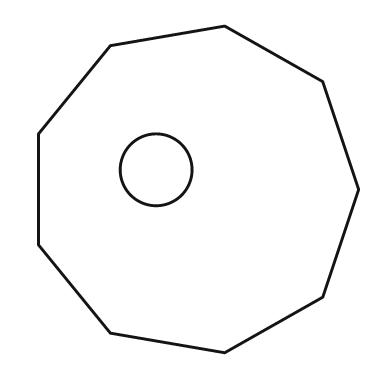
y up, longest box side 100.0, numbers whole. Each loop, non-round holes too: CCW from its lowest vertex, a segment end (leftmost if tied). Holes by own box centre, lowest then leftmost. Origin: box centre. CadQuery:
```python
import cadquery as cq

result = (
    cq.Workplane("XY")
    .moveTo(8.0, -50.0)
    .lineTo(38.0, -33.0)
    .lineTo(49.0, 0.0)
    .lineTo(38.0, 33.0)
    .lineTo(8.0, 50.0)
    .lineTo(-27.0, 44.0)
    .lineTo(-49.0, 17.0)
    .lineTo(-49.0, -17.0)
    .lineTo(-27.0, -44.0)
    .close()
    .moveTo(-13.0, 6.0)
    .circle(11.0)
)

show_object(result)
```